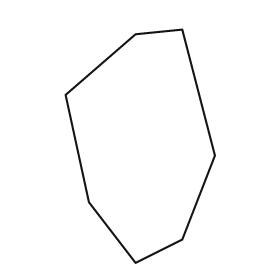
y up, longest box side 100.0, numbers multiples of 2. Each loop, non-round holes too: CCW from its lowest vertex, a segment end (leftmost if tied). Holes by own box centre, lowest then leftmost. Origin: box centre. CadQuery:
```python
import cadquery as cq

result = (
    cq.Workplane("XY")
    .moveTo(-2.0, -50.0)
    .lineTo(18.0, -40.0)
    .lineTo(32.0, -4.0)
    .lineTo(18.0, 50.0)
    .lineTo(-2.0, 48.0)
    .lineTo(-32.0, 22.0)
    .lineTo(-22.0, -24.0)
    .close()
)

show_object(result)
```